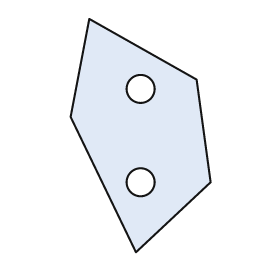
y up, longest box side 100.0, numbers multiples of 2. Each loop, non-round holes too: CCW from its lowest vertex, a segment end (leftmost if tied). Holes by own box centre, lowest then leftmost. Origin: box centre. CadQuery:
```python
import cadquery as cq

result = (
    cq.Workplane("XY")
    .moveTo(-2.0, -50.0)
    .lineTo(30.0, -20.0)
    .lineTo(24.0, 24.0)
    .lineTo(-22.0, 50.0)
    .lineTo(-30.0, 8.0)
    .close()
    .moveTo(0.0, -20.0)
    .circle(6.0)
    .moveTo(0.0, 20.0)
    .circle(6.0)
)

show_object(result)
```